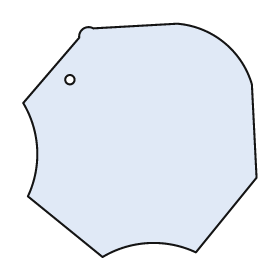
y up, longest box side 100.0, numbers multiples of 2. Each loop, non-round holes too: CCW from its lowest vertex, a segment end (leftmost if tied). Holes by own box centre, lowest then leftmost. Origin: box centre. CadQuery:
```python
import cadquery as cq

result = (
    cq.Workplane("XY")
    .moveTo(-16.0, -50.0)
    .threePointArc((4.0, -44.0), (24.0, -48.0))
    .lineTo(50.0, -16.0)
    .lineTo(48.0, 24.0)
    .threePointArc((36.0, 42.0), (16.0, 50.0))
    .lineTo(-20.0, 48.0)
    .threePointArc((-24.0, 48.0), (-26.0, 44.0))
    .lineTo(-50.0, 16.0)
    .threePointArc((-44.0, -4.0), (-48.0, -24.0))
    .close()
    .moveTo(-30.0, 26.0)
    .circle(2.0)
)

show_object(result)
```